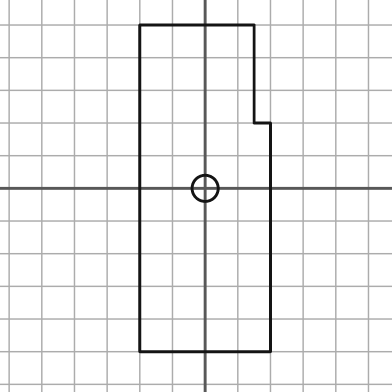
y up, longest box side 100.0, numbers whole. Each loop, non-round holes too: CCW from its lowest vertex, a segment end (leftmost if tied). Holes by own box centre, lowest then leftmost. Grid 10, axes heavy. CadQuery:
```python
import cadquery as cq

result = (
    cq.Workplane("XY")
    .moveTo(-20.0, -50.0)
    .lineTo(20.0, -50.0)
    .lineTo(20.0, 20.0)
    .lineTo(15.0, 20.0)
    .lineTo(15.0, 50.0)
    .lineTo(-20.0, 50.0)
    .close()
    .moveTo(0.0, 0.0)
    .circle(4.0)
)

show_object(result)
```